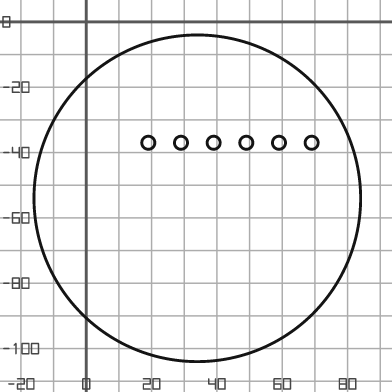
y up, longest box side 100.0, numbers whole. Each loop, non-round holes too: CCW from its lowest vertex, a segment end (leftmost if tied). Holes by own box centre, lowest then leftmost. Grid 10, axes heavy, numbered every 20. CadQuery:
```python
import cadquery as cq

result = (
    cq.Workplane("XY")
    .moveTo(34.0, -54.0)
    .circle(50.0)
    .moveTo(19.0, -37.0)
    .circle(2.0)
    .moveTo(29.0, -37.0)
    .circle(2.0)
    .moveTo(39.0, -37.0)
    .circle(2.0)
    .moveTo(49.0, -37.0)
    .circle(2.0)
    .moveTo(59.0, -37.0)
    .circle(2.0)
    .moveTo(69.0, -37.0)
    .circle(2.0)
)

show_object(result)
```